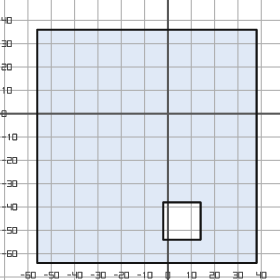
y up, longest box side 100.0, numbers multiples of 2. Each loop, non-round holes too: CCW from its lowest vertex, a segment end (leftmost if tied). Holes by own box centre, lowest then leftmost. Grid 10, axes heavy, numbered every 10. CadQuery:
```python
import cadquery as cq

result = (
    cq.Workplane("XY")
    .moveTo(-56.0, -64.0)
    .lineTo(38.0, -64.0)
    .lineTo(38.0, 36.0)
    .lineTo(-56.0, 36.0)
    .close()
    .moveTo(-2.0, -54.0)
    .lineTo(14.0, -54.0)
    .lineTo(14.0, -38.0)
    .lineTo(-2.0, -38.0)
    .close()
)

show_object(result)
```